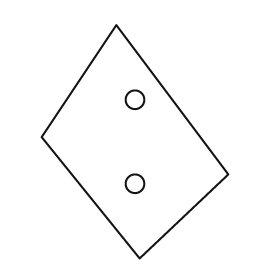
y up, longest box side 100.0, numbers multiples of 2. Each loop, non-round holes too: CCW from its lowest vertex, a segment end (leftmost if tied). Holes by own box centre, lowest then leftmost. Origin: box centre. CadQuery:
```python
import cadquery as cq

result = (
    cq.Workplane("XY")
    .moveTo(2.0, -50.0)
    .lineTo(40.0, -14.0)
    .lineTo(-8.0, 50.0)
    .lineTo(-40.0, 2.0)
    .close()
    .moveTo(0.0, -18.0)
    .circle(4.0)
    .moveTo(0.0, 18.0)
    .circle(4.0)
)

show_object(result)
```